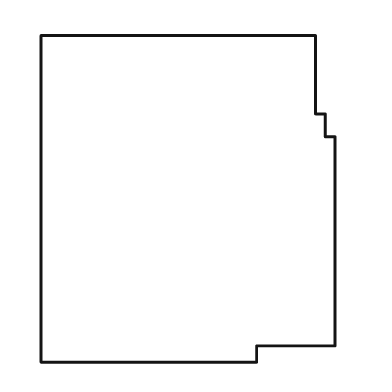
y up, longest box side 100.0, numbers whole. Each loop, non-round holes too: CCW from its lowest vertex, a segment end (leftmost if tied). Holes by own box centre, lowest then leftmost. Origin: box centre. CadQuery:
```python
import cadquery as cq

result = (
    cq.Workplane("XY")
    .moveTo(-45.0, -50.0)
    .lineTo(21.0, -50.0)
    .lineTo(21.0, -45.0)
    .lineTo(45.0, -45.0)
    .lineTo(45.0, 19.0)
    .lineTo(42.0, 19.0)
    .lineTo(42.0, 26.0)
    .lineTo(39.0, 26.0)
    .lineTo(39.0, 50.0)
    .lineTo(-45.0, 50.0)
    .close()
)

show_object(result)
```